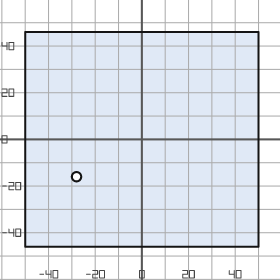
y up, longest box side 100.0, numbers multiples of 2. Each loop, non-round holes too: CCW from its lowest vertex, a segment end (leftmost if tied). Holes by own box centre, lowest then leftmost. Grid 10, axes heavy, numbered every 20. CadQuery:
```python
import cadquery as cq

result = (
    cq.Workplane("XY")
    .moveTo(-50.0, -46.0)
    .lineTo(50.0, -46.0)
    .lineTo(50.0, 46.0)
    .lineTo(-50.0, 46.0)
    .close()
    .moveTo(-28.0, -16.0)
    .circle(2.0)
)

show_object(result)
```